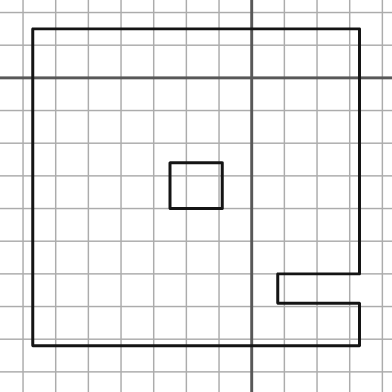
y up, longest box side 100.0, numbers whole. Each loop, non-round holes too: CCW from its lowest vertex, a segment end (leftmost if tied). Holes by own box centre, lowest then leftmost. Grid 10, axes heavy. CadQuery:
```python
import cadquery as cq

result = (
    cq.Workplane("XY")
    .moveTo(-67.0, -82.0)
    .lineTo(33.0, -82.0)
    .lineTo(33.0, -69.0)
    .lineTo(8.0, -69.0)
    .lineTo(8.0, -60.0)
    .lineTo(33.0, -60.0)
    .lineTo(33.0, 15.0)
    .lineTo(-67.0, 15.0)
    .close()
    .moveTo(-25.0, -40.0)
    .lineTo(-9.0, -40.0)
    .lineTo(-9.0, -26.0)
    .lineTo(-25.0, -26.0)
    .close()
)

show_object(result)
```